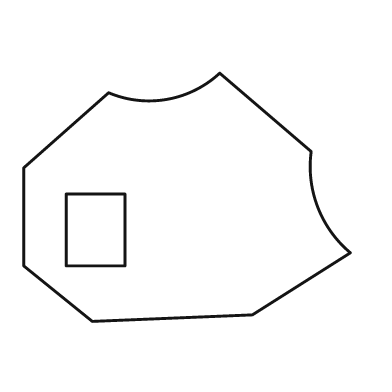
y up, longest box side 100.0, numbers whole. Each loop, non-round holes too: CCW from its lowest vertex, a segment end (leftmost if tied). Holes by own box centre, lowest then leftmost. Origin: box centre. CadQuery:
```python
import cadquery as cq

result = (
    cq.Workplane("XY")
    .moveTo(-29.0, -38.0)
    .lineTo(20.0, -36.0)
    .lineTo(50.0, -17.0)
    .threePointArc((40.0, -3.0), (38.0, 14.0))
    .lineTo(10.0, 38.0)
    .threePointArc((-6.0, 30.0), (-24.0, 32.0))
    .lineTo(-50.0, 9.0)
    .lineTo(-50.0, -21.0)
    .close()
    .moveTo(-37.0, -21.0)
    .lineTo(-19.0, -21.0)
    .lineTo(-19.0, 1.0)
    .lineTo(-37.0, 1.0)
    .close()
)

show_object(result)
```